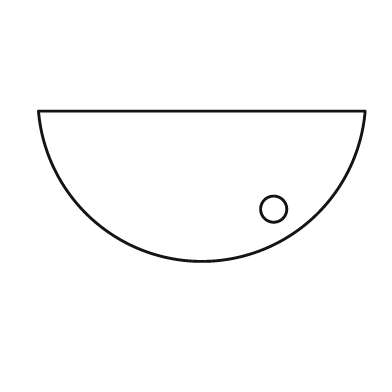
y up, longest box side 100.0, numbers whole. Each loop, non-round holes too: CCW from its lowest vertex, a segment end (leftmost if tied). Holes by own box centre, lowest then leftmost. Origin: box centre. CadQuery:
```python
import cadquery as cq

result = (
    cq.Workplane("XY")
    .moveTo(-50.0, 23.0)
    .threePointArc((0.0, -23.0), (50.0, 23.0))
    .close()
    .moveTo(22.0, -7.0)
    .circle(4.0)
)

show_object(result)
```